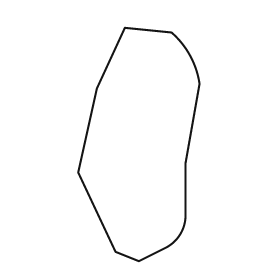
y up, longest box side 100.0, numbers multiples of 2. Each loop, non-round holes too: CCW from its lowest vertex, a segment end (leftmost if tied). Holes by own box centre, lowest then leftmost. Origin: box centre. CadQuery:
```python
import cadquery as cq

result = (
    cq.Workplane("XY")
    .moveTo(0.0, -50.0)
    .lineTo(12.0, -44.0)
    .threePointArc((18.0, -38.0), (20.0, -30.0))
    .lineTo(20.0, -8.0)
    .lineTo(26.0, 26.0)
    .threePointArc((22.0, 38.0), (14.0, 48.0))
    .lineTo(-6.0, 50.0)
    .lineTo(-18.0, 24.0)
    .lineTo(-26.0, -12.0)
    .lineTo(-10.0, -46.0)
    .close()
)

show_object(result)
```